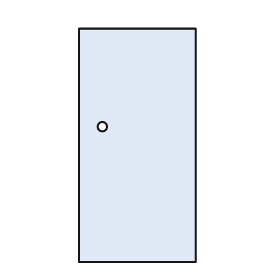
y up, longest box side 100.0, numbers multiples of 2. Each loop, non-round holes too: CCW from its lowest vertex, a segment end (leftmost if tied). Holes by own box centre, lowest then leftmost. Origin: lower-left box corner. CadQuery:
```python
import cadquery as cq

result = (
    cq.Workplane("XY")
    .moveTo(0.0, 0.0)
    .lineTo(50.0, 0.0)
    .lineTo(50.0, 100.0)
    .lineTo(0.0, 100.0)
    .close()
    .moveTo(10.0, 58.0)
    .circle(2.0)
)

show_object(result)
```